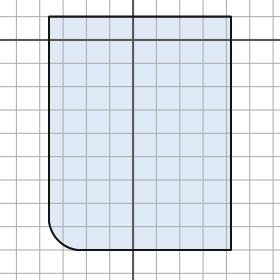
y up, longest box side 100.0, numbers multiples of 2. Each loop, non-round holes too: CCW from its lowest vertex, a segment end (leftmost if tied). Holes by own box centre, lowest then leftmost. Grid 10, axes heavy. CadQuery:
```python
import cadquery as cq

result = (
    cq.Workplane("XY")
    .moveTo(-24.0, -90.0)
    .lineTo(42.0, -90.0)
    .lineTo(42.0, 10.0)
    .lineTo(-36.0, 10.0)
    .lineTo(-36.0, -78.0)
    .threePointArc((-32.0, -86.0), (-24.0, -90.0))
    .close()
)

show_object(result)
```